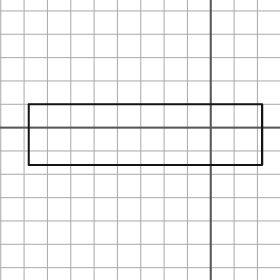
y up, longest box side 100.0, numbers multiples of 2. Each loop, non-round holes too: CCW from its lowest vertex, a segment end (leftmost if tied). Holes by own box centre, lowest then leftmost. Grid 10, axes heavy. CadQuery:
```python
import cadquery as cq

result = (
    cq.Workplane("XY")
    .moveTo(-78.0, -16.0)
    .lineTo(22.0, -16.0)
    .lineTo(22.0, 10.0)
    .lineTo(-78.0, 10.0)
    .close()
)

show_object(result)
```